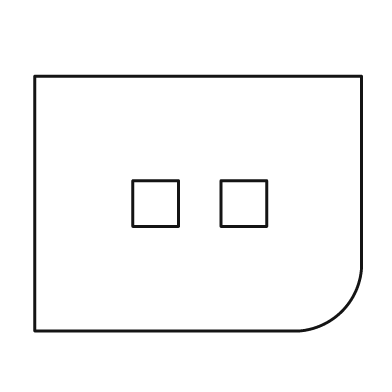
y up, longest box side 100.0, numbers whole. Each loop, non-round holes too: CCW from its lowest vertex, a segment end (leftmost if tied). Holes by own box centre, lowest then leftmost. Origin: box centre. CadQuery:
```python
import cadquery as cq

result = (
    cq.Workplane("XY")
    .moveTo(-50.0, -39.0)
    .lineTo(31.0, -39.0)
    .threePointArc((44.0, -33.0), (50.0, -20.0))
    .lineTo(50.0, 39.0)
    .lineTo(-50.0, 39.0)
    .close()
    .moveTo(-20.0, -7.0)
    .lineTo(-6.0, -7.0)
    .lineTo(-6.0, 7.0)
    .lineTo(-20.0, 7.0)
    .close()
    .moveTo(7.0, -7.0)
    .lineTo(21.0, -7.0)
    .lineTo(21.0, 7.0)
    .lineTo(7.0, 7.0)
    .close()
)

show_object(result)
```